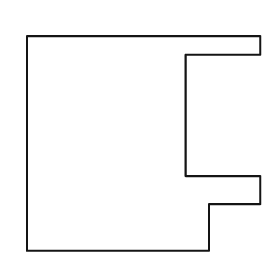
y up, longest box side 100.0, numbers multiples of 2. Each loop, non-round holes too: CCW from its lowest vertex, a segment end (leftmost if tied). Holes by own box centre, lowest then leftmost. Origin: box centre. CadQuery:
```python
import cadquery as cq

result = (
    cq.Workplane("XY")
    .moveTo(-50.0, -46.0)
    .lineTo(28.0, -46.0)
    .lineTo(28.0, -26.0)
    .lineTo(50.0, -26.0)
    .lineTo(50.0, -14.0)
    .lineTo(18.0, -14.0)
    .lineTo(18.0, 38.0)
    .lineTo(50.0, 38.0)
    .lineTo(50.0, 46.0)
    .lineTo(-50.0, 46.0)
    .close()
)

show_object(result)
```